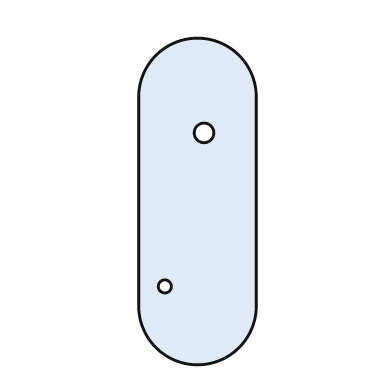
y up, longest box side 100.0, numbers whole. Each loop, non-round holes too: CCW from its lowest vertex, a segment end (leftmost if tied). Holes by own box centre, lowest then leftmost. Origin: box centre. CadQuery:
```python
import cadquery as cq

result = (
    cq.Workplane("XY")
    .moveTo(-18.0, -32.0)
    .threePointArc((0.0, -50.0), (18.0, -32.0))
    .lineTo(18.0, 32.0)
    .threePointArc((0.0, 50.0), (-18.0, 32.0))
    .close()
    .moveTo(-10.0, -26.0)
    .circle(2.0)
    .moveTo(2.0, 21.0)
    .circle(3.0)
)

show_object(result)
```